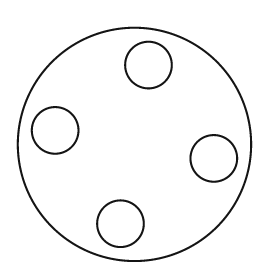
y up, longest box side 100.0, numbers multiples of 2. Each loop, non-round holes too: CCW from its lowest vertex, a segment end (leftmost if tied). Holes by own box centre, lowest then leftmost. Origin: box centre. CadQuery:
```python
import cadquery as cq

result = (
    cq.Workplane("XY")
    .moveTo(0.0, 0.0)
    .circle(50.0)
    .moveTo(-6.0, -34.0)
    .circle(10.0)
    .moveTo(34.0, -6.0)
    .circle(10.0)
    .moveTo(-34.0, 6.0)
    .circle(10.0)
    .moveTo(6.0, 34.0)
    .circle(10.0)
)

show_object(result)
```